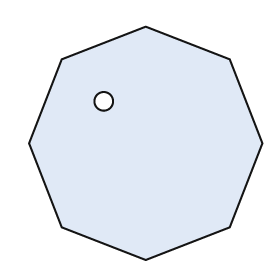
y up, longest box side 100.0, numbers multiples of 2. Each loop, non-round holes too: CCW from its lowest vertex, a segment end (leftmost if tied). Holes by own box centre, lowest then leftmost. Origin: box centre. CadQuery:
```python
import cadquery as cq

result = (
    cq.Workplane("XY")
    .moveTo(0.0, -50.0)
    .lineTo(36.0, -36.0)
    .lineTo(50.0, 0.0)
    .lineTo(36.0, 36.0)
    .lineTo(0.0, 50.0)
    .lineTo(-36.0, 36.0)
    .lineTo(-50.0, 0.0)
    .lineTo(-36.0, -36.0)
    .close()
    .moveTo(-18.0, 18.0)
    .circle(4.0)
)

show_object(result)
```